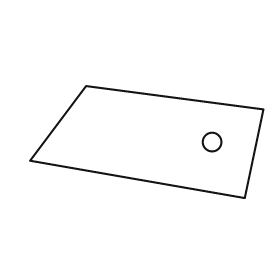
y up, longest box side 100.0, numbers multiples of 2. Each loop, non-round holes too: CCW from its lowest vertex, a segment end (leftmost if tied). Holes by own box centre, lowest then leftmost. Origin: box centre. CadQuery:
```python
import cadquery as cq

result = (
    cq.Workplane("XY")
    .moveTo(42.0, -24.0)
    .lineTo(50.0, 14.0)
    .lineTo(-26.0, 24.0)
    .lineTo(-50.0, -8.0)
    .close()
    .moveTo(28.0, 0.0)
    .circle(4.0)
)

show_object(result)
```